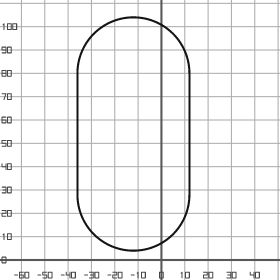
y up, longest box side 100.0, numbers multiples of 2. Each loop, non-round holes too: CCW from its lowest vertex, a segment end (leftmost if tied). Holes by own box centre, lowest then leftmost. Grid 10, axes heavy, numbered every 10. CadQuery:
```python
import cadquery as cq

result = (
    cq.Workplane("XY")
    .moveTo(-36.0, 28.0)
    .threePointArc((-12.0, 4.0), (12.0, 28.0))
    .lineTo(12.0, 80.0)
    .threePointArc((-12.0, 104.0), (-36.0, 80.0))
    .close()
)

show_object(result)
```